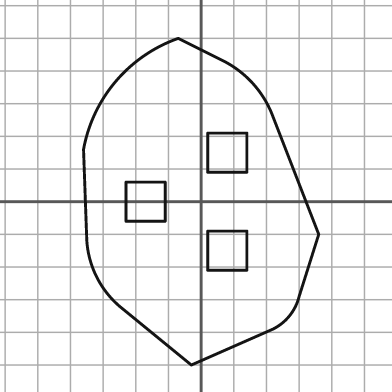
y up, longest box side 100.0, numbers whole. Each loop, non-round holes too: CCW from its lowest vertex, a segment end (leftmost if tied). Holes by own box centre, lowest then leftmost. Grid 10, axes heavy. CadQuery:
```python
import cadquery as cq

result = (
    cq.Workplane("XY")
    .moveTo(-3.0, -50.0)
    .lineTo(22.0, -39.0)
    .threePointArc((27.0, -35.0), (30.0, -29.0))
    .lineTo(36.0, -10.0)
    .lineTo(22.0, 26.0)
    .threePointArc((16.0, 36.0), (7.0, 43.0))
    .lineTo(-7.0, 50.0)
    .threePointArc((-26.0, 37.0), (-36.0, 16.0))
    .lineTo(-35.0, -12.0)
    .threePointArc((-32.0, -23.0), (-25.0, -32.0))
    .close()
    .moveTo(2.0, -21.0)
    .lineTo(14.0, -21.0)
    .lineTo(14.0, -9.0)
    .lineTo(2.0, -9.0)
    .close()
    .moveTo(-23.0, -6.0)
    .lineTo(-11.0, -6.0)
    .lineTo(-11.0, 6.0)
    .lineTo(-23.0, 6.0)
    .close()
    .moveTo(2.0, 9.0)
    .lineTo(14.0, 9.0)
    .lineTo(14.0, 21.0)
    .lineTo(2.0, 21.0)
    .close()
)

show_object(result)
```